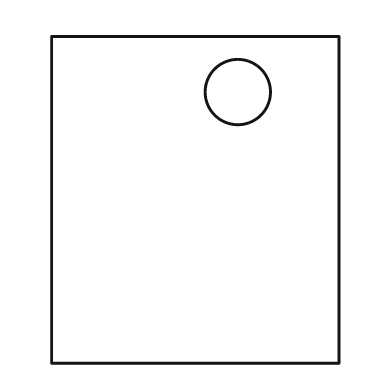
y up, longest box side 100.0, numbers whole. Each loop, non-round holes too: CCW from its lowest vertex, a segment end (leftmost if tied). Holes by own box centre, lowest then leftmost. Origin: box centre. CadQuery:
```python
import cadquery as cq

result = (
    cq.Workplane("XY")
    .moveTo(-44.0, -50.0)
    .lineTo(44.0, -50.0)
    .lineTo(44.0, 50.0)
    .lineTo(-44.0, 50.0)
    .close()
    .moveTo(13.0, 33.0)
    .circle(10.0)
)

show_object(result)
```